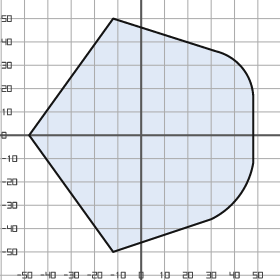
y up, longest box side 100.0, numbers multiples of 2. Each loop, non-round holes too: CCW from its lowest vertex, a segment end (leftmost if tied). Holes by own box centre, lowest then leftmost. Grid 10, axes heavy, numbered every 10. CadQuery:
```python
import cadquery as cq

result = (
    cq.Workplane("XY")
    .moveTo(-12.0, -50.0)
    .lineTo(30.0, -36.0)
    .threePointArc((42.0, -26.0), (48.0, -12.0))
    .lineTo(48.0, 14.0)
    .threePointArc((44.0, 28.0), (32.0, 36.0))
    .lineTo(-12.0, 50.0)
    .lineTo(-48.0, 0.0)
    .close()
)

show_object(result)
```